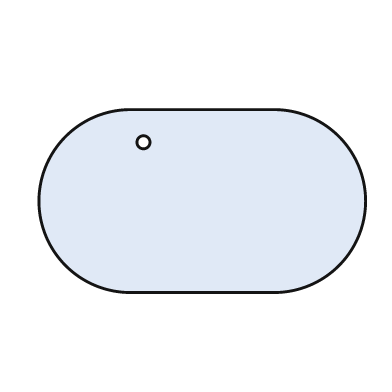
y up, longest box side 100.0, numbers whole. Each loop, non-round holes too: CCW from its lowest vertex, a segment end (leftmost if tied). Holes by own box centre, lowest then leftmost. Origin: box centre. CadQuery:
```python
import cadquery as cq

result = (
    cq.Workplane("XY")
    .moveTo(-22.0, -28.0)
    .lineTo(22.0, -28.0)
    .threePointArc((50.0, 0.0), (22.0, 28.0))
    .lineTo(-22.0, 28.0)
    .threePointArc((-50.0, 0.0), (-22.0, -28.0))
    .close()
    .moveTo(-18.0, 18.0)
    .circle(2.0)
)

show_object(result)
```